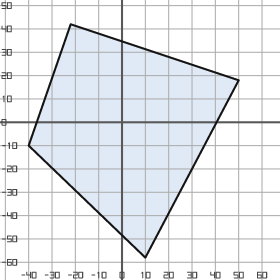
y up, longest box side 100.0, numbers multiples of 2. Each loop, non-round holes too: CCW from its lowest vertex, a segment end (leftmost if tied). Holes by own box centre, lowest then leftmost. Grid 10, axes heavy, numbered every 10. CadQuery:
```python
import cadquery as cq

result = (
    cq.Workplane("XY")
    .moveTo(10.0, -58.0)
    .lineTo(50.0, 18.0)
    .lineTo(-22.0, 42.0)
    .lineTo(-40.0, -10.0)
    .close()
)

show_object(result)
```